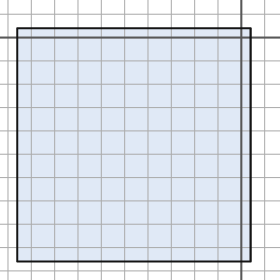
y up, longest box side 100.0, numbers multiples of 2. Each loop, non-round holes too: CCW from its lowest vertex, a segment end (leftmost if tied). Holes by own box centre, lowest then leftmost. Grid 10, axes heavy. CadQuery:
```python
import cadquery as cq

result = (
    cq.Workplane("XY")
    .moveTo(-96.0, -96.0)
    .lineTo(4.0, -96.0)
    .lineTo(4.0, 4.0)
    .lineTo(-96.0, 4.0)
    .close()
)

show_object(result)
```